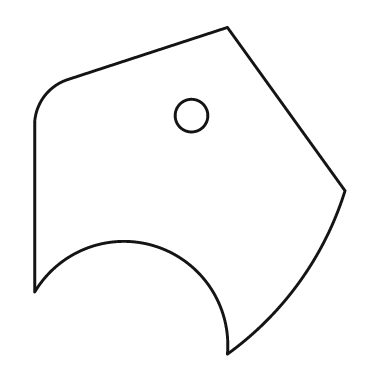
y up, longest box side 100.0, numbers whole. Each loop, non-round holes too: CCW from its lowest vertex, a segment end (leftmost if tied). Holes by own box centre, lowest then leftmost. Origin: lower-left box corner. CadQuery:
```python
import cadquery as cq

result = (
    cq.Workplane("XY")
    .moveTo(59.0, 0.0)
    .threePointArc((81.0, 22.0), (95.0, 50.0))
    .lineTo(59.0, 100.0)
    .lineTo(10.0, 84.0)
    .threePointArc((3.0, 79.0), (0.0, 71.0))
    .lineTo(0.0, 19.0)
    .threePointArc((37.0, 33.0), (59.0, 0.0))
    .close()
    .moveTo(48.0, 73.0)
    .circle(5.0)
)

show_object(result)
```